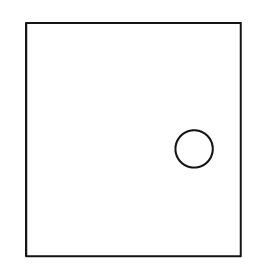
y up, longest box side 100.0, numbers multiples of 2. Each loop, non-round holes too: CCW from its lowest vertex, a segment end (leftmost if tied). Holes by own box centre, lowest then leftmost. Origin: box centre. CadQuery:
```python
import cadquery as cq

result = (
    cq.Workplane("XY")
    .moveTo(-46.0, -50.0)
    .lineTo(46.0, -50.0)
    .lineTo(46.0, 50.0)
    .lineTo(-46.0, 50.0)
    .close()
    .moveTo(26.0, -4.0)
    .circle(8.0)
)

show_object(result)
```